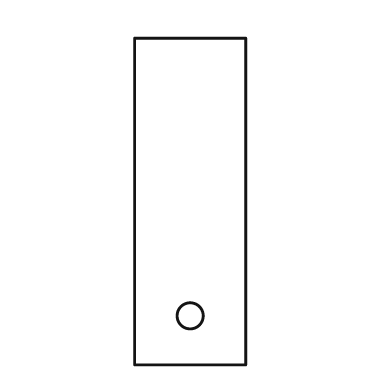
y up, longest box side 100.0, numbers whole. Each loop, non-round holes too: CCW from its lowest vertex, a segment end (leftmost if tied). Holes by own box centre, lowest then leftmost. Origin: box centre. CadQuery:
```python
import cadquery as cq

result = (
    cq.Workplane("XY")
    .moveTo(-17.0, -50.0)
    .lineTo(17.0, -50.0)
    .lineTo(17.0, 50.0)
    .lineTo(-17.0, 50.0)
    .close()
    .moveTo(0.0, -35.0)
    .circle(4.0)
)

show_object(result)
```